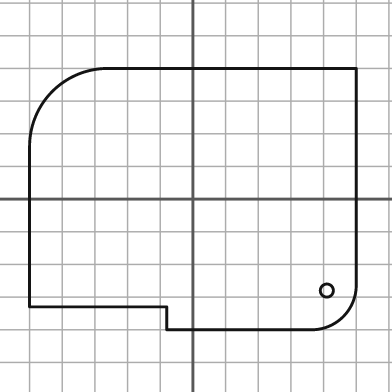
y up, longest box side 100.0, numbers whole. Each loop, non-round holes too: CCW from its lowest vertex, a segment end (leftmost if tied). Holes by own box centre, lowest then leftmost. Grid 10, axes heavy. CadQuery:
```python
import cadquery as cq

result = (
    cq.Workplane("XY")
    .moveTo(-8.0, -40.0)
    .lineTo(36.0, -40.0)
    .threePointArc((46.0, -36.0), (50.0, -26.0))
    .lineTo(50.0, 40.0)
    .lineTo(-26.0, 40.0)
    .threePointArc((-43.0, 33.0), (-50.0, 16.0))
    .lineTo(-50.0, -33.0)
    .lineTo(-8.0, -33.0)
    .close()
    .moveTo(41.0, -28.0)
    .circle(2.0)
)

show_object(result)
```